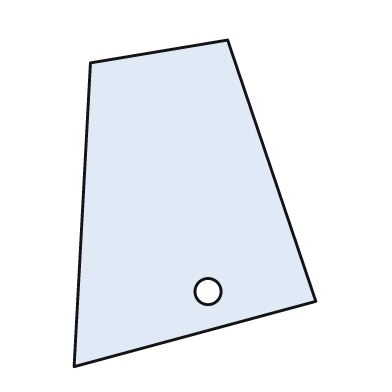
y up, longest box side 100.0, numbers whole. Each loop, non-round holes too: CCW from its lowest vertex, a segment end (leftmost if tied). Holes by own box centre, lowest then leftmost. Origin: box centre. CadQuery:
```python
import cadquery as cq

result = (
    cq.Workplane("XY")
    .moveTo(-37.0, -50.0)
    .lineTo(37.0, -30.0)
    .lineTo(10.0, 50.0)
    .lineTo(-32.0, 43.0)
    .close()
    .moveTo(4.0, -27.0)
    .circle(4.0)
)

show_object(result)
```